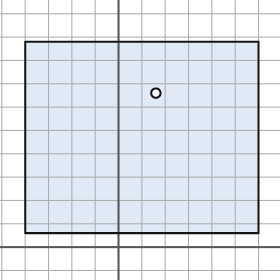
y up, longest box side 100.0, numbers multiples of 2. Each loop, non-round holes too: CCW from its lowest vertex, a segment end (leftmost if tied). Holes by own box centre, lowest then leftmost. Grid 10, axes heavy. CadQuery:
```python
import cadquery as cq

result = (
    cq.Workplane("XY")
    .moveTo(-40.0, 6.0)
    .lineTo(60.0, 6.0)
    .lineTo(60.0, 88.0)
    .lineTo(-40.0, 88.0)
    .close()
    .moveTo(16.0, 66.0)
    .circle(2.0)
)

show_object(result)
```